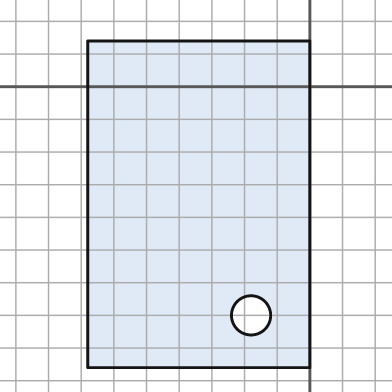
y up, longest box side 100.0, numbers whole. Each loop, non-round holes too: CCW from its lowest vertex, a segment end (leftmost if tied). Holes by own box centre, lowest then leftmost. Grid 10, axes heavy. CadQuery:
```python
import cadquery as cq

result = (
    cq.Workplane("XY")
    .moveTo(-68.0, -86.0)
    .lineTo(0.0, -86.0)
    .lineTo(0.0, 14.0)
    .lineTo(-68.0, 14.0)
    .close()
    .moveTo(-18.0, -70.0)
    .circle(6.0)
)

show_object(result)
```